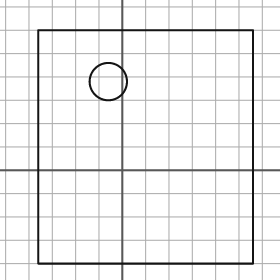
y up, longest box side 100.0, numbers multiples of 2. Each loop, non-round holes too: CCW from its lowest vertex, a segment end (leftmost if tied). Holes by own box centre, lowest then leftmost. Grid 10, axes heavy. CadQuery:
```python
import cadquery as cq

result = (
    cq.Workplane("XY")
    .moveTo(-36.0, -40.0)
    .lineTo(56.0, -40.0)
    .lineTo(56.0, 60.0)
    .lineTo(-36.0, 60.0)
    .close()
    .moveTo(-6.0, 38.0)
    .circle(8.0)
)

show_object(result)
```